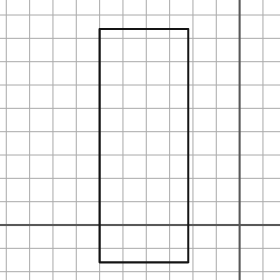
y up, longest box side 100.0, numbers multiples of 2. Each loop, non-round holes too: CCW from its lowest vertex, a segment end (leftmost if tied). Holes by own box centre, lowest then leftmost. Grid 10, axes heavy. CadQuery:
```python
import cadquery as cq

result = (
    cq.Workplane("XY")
    .moveTo(-60.0, -16.0)
    .lineTo(-22.0, -16.0)
    .lineTo(-22.0, 84.0)
    .lineTo(-60.0, 84.0)
    .close()
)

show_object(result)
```